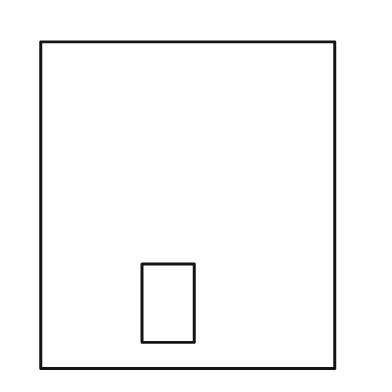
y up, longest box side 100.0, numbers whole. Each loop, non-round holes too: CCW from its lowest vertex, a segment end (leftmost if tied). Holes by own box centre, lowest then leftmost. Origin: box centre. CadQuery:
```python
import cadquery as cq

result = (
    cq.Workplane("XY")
    .moveTo(-45.0, -50.0)
    .lineTo(45.0, -50.0)
    .lineTo(45.0, 50.0)
    .lineTo(-45.0, 50.0)
    .close()
    .moveTo(-14.0, -42.0)
    .lineTo(2.0, -42.0)
    .lineTo(2.0, -18.0)
    .lineTo(-14.0, -18.0)
    .close()
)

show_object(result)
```